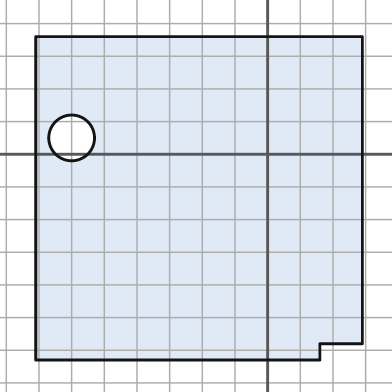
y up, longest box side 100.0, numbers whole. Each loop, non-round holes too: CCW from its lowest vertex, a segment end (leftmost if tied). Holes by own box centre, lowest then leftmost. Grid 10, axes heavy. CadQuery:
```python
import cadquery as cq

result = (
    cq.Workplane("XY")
    .moveTo(-71.0, -63.0)
    .lineTo(16.0, -63.0)
    .lineTo(16.0, -58.0)
    .lineTo(29.0, -58.0)
    .lineTo(29.0, 36.0)
    .lineTo(-71.0, 36.0)
    .close()
    .moveTo(-60.0, 5.0)
    .circle(7.0)
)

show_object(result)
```